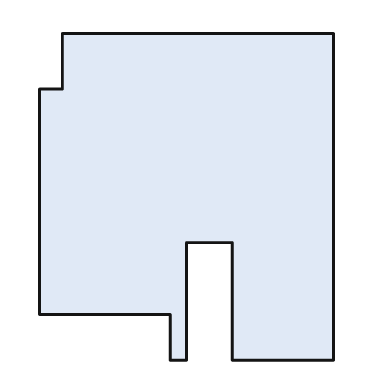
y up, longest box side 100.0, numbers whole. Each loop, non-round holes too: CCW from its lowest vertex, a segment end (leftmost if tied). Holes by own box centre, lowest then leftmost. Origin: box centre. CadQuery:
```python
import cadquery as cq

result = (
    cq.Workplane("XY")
    .moveTo(-5.0, -50.0)
    .lineTo(0.0, -50.0)
    .lineTo(0.0, -14.0)
    .lineTo(14.0, -14.0)
    .lineTo(14.0, -50.0)
    .lineTo(45.0, -50.0)
    .lineTo(45.0, 50.0)
    .lineTo(-38.0, 50.0)
    .lineTo(-38.0, 33.0)
    .lineTo(-45.0, 33.0)
    .lineTo(-45.0, -36.0)
    .lineTo(-5.0, -36.0)
    .close()
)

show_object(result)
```